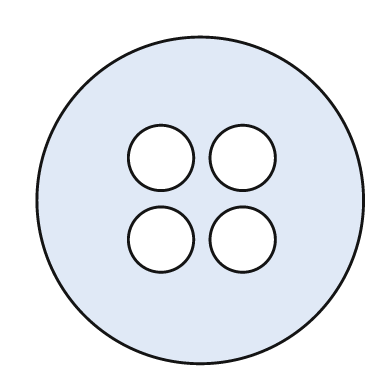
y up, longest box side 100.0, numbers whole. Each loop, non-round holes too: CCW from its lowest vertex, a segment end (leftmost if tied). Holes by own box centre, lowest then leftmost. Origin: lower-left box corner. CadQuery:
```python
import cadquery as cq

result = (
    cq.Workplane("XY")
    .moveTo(50.0, 50.0)
    .circle(50.0)
    .moveTo(38.0, 38.0)
    .circle(10.0)
    .moveTo(63.0, 38.0)
    .circle(10.0)
    .moveTo(38.0, 63.0)
    .circle(10.0)
    .moveTo(63.0, 63.0)
    .circle(10.0)
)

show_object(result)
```